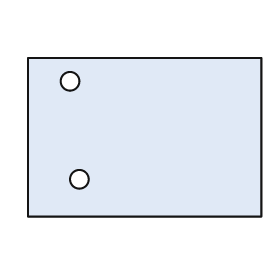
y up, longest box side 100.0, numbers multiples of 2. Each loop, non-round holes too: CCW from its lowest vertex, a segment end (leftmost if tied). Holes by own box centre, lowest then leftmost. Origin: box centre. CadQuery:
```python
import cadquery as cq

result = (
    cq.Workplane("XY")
    .moveTo(-50.0, -34.0)
    .lineTo(50.0, -34.0)
    .lineTo(50.0, 34.0)
    .lineTo(-50.0, 34.0)
    .close()
    .moveTo(-28.0, -18.0)
    .circle(4.0)
    .moveTo(-32.0, 24.0)
    .circle(4.0)
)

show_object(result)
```